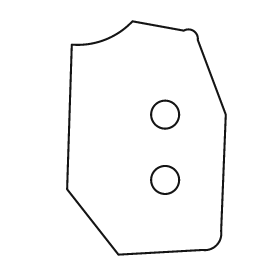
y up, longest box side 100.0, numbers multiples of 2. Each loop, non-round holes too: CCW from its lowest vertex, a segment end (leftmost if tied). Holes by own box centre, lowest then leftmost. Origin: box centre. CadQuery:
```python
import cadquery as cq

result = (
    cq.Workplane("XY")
    .moveTo(-12.0, -50.0)
    .lineTo(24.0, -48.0)
    .threePointArc((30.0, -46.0), (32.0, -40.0))
    .lineTo(34.0, 10.0)
    .lineTo(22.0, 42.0)
    .threePointArc((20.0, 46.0), (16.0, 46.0))
    .lineTo(-6.0, 50.0)
    .threePointArc((-18.0, 42.0), (-32.0, 40.0))
    .lineTo(-34.0, -22.0)
    .close()
    .moveTo(8.0, -18.0)
    .circle(6.0)
    .moveTo(8.0, 10.0)
    .circle(6.0)
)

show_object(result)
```